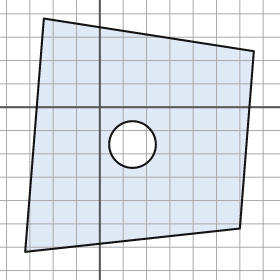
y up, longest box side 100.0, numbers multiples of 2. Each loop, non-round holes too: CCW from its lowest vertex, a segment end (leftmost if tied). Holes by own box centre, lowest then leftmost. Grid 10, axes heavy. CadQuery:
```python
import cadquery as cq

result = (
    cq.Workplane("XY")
    .moveTo(-32.0, -62.0)
    .lineTo(60.0, -52.0)
    .lineTo(66.0, 24.0)
    .lineTo(-24.0, 38.0)
    .close()
    .moveTo(14.0, -16.0)
    .circle(10.0)
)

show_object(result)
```